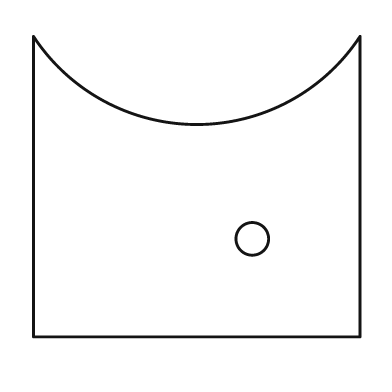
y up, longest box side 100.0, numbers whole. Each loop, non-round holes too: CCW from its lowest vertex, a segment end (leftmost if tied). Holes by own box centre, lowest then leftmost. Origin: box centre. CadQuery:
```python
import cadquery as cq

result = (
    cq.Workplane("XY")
    .moveTo(-50.0, -46.0)
    .lineTo(50.0, -46.0)
    .lineTo(50.0, 46.0)
    .threePointArc((0.0, 19.0), (-50.0, 46.0))
    .close()
    .moveTo(17.0, -16.0)
    .circle(5.0)
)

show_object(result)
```